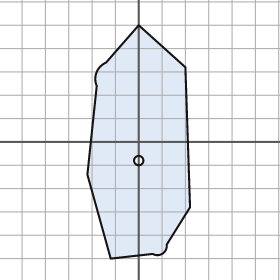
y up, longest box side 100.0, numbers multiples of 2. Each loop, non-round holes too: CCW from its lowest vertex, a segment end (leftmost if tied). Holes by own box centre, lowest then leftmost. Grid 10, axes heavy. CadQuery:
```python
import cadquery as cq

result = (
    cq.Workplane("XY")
    .moveTo(-12.0, -50.0)
    .lineTo(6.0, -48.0)
    .threePointArc((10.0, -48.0), (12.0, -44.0))
    .lineTo(22.0, -28.0)
    .lineTo(20.0, 32.0)
    .lineTo(0.0, 50.0)
    .lineTo(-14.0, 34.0)
    .threePointArc((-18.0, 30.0), (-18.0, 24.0))
    .lineTo(-22.0, -14.0)
    .close()
    .moveTo(0.0, -8.0)
    .circle(2.0)
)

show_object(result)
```